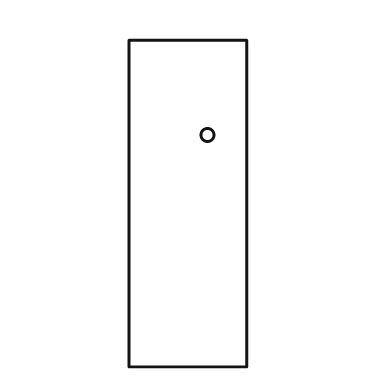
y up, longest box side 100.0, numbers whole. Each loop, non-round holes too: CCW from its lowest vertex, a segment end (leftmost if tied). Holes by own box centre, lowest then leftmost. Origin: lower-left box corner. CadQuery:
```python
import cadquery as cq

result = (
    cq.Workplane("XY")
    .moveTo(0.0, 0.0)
    .lineTo(36.0, 0.0)
    .lineTo(36.0, 100.0)
    .lineTo(0.0, 100.0)
    .close()
    .moveTo(24.0, 71.0)
    .circle(2.0)
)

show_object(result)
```